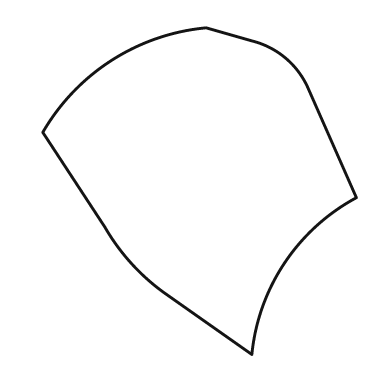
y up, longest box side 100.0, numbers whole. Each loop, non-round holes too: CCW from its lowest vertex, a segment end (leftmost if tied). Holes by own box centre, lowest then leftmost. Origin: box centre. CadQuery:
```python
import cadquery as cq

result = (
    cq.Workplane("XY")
    .moveTo(16.0, -50.0)
    .threePointArc((26.0, -22.0), (48.0, -2.0))
    .lineTo(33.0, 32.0)
    .threePointArc((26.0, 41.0), (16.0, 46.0))
    .lineTo(2.0, 50.0)
    .threePointArc((-27.0, 40.0), (-48.0, 18.0))
    .lineTo(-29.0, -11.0)
    .threePointArc((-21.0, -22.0), (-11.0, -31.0))
    .close()
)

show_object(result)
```